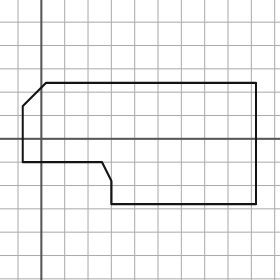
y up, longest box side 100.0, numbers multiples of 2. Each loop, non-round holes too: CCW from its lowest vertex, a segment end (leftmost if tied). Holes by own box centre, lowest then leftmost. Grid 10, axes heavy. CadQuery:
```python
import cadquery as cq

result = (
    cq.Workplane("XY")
    .moveTo(30.0, -28.0)
    .lineTo(92.0, -28.0)
    .lineTo(92.0, 24.0)
    .lineTo(2.0, 24.0)
    .lineTo(-8.0, 14.0)
    .lineTo(-8.0, -10.0)
    .lineTo(26.0, -10.0)
    .lineTo(30.0, -18.0)
    .close()
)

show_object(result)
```